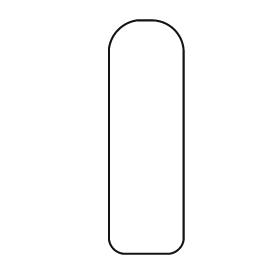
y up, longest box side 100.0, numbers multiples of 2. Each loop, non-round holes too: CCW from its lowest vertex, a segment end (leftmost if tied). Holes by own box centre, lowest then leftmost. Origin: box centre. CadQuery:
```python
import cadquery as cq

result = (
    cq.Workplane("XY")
    .moveTo(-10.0, -50.0)
    .lineTo(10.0, -50.0)
    .threePointArc((14.0, -48.0), (16.0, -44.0))
    .lineTo(16.0, 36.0)
    .threePointArc((12.0, 46.0), (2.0, 50.0))
    .lineTo(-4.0, 50.0)
    .threePointArc((-12.0, 46.0), (-16.0, 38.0))
    .lineTo(-16.0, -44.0)
    .threePointArc((-14.0, -48.0), (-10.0, -50.0))
    .close()
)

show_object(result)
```